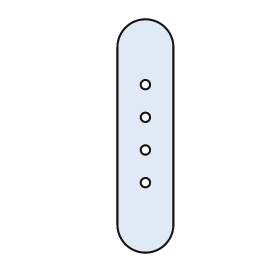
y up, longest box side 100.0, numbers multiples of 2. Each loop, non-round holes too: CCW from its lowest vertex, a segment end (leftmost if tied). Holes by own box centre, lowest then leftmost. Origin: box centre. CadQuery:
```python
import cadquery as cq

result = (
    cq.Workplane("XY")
    .moveTo(-12.0, -38.0)
    .threePointArc((0.0, -50.0), (12.0, -38.0))
    .lineTo(12.0, 38.0)
    .threePointArc((0.0, 50.0), (-12.0, 38.0))
    .close()
    .moveTo(0.0, -20.0)
    .circle(2.0)
    .moveTo(0.0, -6.0)
    .circle(2.0)
    .moveTo(0.0, 8.0)
    .circle(2.0)
    .moveTo(0.0, 22.0)
    .circle(2.0)
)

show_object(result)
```